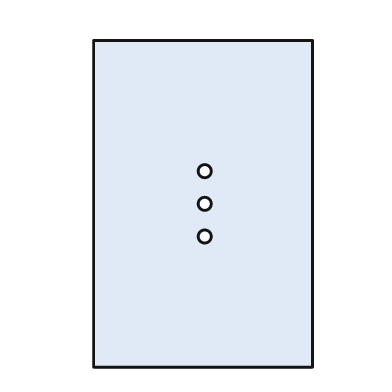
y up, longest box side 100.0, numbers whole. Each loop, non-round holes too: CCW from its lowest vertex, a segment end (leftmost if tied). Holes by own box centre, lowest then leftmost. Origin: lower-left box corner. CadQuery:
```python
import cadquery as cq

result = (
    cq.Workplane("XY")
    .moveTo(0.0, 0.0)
    .lineTo(67.0, 0.0)
    .lineTo(67.0, 100.0)
    .lineTo(0.0, 100.0)
    .close()
    .moveTo(34.0, 40.0)
    .circle(2.0)
    .moveTo(34.0, 50.0)
    .circle(2.0)
    .moveTo(34.0, 60.0)
    .circle(2.0)
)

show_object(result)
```